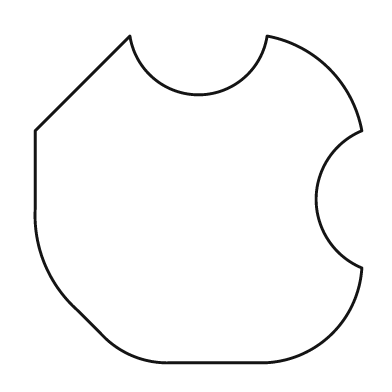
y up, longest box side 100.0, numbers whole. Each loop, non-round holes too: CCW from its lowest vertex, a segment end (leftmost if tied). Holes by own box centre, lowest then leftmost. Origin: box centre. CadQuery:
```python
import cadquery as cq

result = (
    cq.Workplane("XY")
    .moveTo(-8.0, -50.0)
    .lineTo(21.0, -50.0)
    .threePointArc((41.0, -41.0), (50.0, -21.0))
    .threePointArc((36.0, 0.0), (50.0, 21.0))
    .threePointArc((40.0, 40.0), (21.0, 50.0))
    .threePointArc((0.0, 32.0), (-21.0, 50.0))
    .lineTo(-50.0, 21.0)
    .lineTo(-50.0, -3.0)
    .threePointArc((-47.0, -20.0), (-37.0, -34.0))
    .lineTo(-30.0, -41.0)
    .threePointArc((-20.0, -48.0), (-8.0, -50.0))
    .close()
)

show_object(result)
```